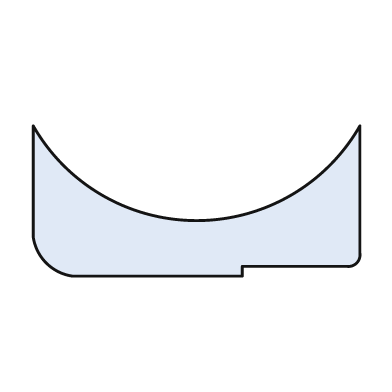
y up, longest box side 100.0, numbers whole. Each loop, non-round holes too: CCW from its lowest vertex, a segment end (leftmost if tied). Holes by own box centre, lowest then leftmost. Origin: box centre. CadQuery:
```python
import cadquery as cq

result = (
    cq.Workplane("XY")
    .moveTo(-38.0, -23.0)
    .lineTo(14.0, -23.0)
    .lineTo(14.0, -20.0)
    .lineTo(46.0, -20.0)
    .threePointArc((49.0, -19.0), (50.0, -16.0))
    .lineTo(50.0, 23.0)
    .threePointArc((0.0, -6.0), (-50.0, 23.0))
    .lineTo(-50.0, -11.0)
    .threePointArc((-46.0, -19.0), (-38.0, -23.0))
    .close()
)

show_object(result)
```